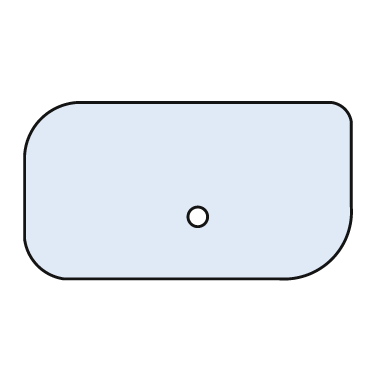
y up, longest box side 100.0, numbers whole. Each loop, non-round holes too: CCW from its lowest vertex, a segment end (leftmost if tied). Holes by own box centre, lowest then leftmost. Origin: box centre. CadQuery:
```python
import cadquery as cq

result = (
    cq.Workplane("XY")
    .moveTo(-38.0, -27.0)
    .lineTo(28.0, -27.0)
    .threePointArc((44.0, -21.0), (50.0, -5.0))
    .lineTo(50.0, 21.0)
    .threePointArc((48.0, 25.0), (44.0, 27.0))
    .lineTo(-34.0, 27.0)
    .threePointArc((-45.0, 22.0), (-50.0, 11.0))
    .lineTo(-50.0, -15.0)
    .threePointArc((-46.0, -23.0), (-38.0, -27.0))
    .close()
    .moveTo(3.0, -8.0)
    .circle(3.0)
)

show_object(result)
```